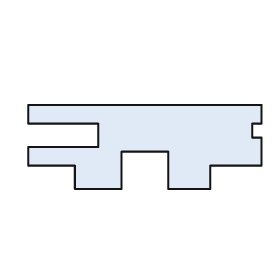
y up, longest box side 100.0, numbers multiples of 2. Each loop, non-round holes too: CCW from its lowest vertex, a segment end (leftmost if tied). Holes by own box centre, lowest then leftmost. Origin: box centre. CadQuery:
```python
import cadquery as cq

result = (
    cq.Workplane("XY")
    .moveTo(-30.0, -18.0)
    .lineTo(-10.0, -18.0)
    .lineTo(-10.0, -2.0)
    .lineTo(10.0, -2.0)
    .lineTo(10.0, -18.0)
    .lineTo(28.0, -18.0)
    .lineTo(28.0, -8.0)
    .lineTo(50.0, -8.0)
    .lineTo(50.0, 4.0)
    .lineTo(46.0, 4.0)
    .lineTo(46.0, 10.0)
    .lineTo(50.0, 10.0)
    .lineTo(50.0, 18.0)
    .lineTo(-50.0, 18.0)
    .lineTo(-50.0, 10.0)
    .lineTo(-20.0, 10.0)
    .lineTo(-20.0, 0.0)
    .lineTo(-50.0, 0.0)
    .lineTo(-50.0, -8.0)
    .lineTo(-30.0, -8.0)
    .close()
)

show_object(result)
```